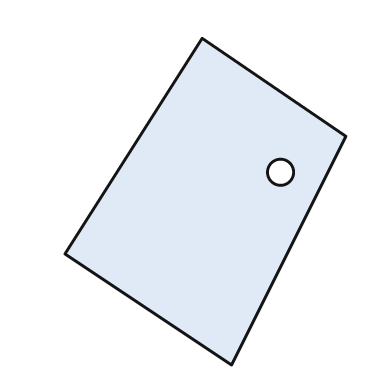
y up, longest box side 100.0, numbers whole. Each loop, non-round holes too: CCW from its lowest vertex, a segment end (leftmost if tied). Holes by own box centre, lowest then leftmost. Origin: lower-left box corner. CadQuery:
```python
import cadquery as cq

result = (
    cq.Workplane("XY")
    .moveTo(51.0, 0.0)
    .lineTo(86.0, 70.0)
    .lineTo(42.0, 100.0)
    .lineTo(0.0, 34.0)
    .close()
    .moveTo(66.0, 59.0)
    .circle(4.0)
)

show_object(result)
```